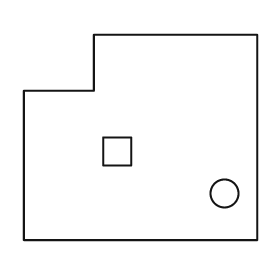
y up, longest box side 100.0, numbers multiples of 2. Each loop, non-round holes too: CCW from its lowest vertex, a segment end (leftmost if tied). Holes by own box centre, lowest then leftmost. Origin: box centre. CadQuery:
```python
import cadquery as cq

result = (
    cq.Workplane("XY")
    .moveTo(-50.0, -44.0)
    .lineTo(50.0, -44.0)
    .lineTo(50.0, 44.0)
    .lineTo(-20.0, 44.0)
    .lineTo(-20.0, 20.0)
    .lineTo(-50.0, 20.0)
    .close()
    .moveTo(36.0, -24.0)
    .circle(6.0)
    .moveTo(-16.0, -12.0)
    .lineTo(-4.0, -12.0)
    .lineTo(-4.0, 0.0)
    .lineTo(-16.0, 0.0)
    .close()
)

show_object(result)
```